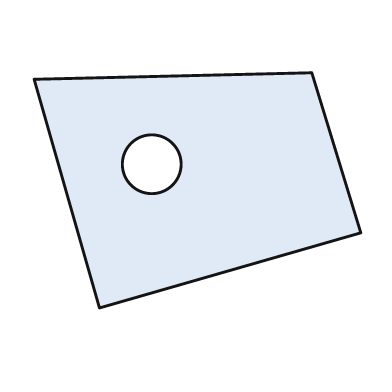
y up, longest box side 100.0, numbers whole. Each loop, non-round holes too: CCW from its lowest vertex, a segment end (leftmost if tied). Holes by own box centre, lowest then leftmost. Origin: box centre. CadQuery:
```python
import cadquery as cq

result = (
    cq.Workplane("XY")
    .moveTo(-30.0, -36.0)
    .lineTo(50.0, -13.0)
    .lineTo(35.0, 36.0)
    .lineTo(-50.0, 34.0)
    .close()
    .moveTo(-14.0, 8.0)
    .circle(9.0)
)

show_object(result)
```